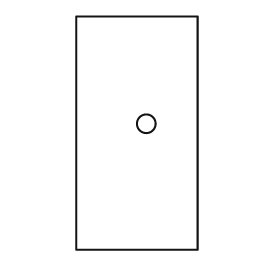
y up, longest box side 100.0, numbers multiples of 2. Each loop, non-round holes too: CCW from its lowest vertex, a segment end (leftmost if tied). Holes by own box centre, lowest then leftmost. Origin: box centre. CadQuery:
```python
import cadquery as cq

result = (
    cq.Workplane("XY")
    .moveTo(-26.0, -50.0)
    .lineTo(26.0, -50.0)
    .lineTo(26.0, 50.0)
    .lineTo(-26.0, 50.0)
    .close()
    .moveTo(4.0, 4.0)
    .circle(4.0)
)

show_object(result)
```